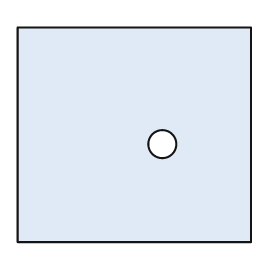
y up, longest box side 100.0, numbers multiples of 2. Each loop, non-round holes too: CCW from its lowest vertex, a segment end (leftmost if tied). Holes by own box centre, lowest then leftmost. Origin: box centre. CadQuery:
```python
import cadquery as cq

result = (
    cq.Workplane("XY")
    .moveTo(-50.0, -46.0)
    .lineTo(50.0, -46.0)
    .lineTo(50.0, 46.0)
    .lineTo(-50.0, 46.0)
    .close()
    .moveTo(12.0, -4.0)
    .circle(6.0)
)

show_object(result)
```